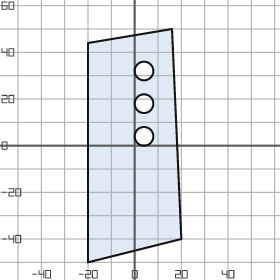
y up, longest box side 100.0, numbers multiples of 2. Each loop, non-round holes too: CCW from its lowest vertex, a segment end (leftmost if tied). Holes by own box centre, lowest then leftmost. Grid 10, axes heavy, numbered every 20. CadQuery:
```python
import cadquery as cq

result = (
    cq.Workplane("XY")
    .moveTo(-20.0, -50.0)
    .lineTo(20.0, -40.0)
    .lineTo(16.0, 50.0)
    .lineTo(-20.0, 44.0)
    .close()
    .moveTo(4.0, 4.0)
    .circle(4.0)
    .moveTo(4.0, 18.0)
    .circle(4.0)
    .moveTo(4.0, 32.0)
    .circle(4.0)
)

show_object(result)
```